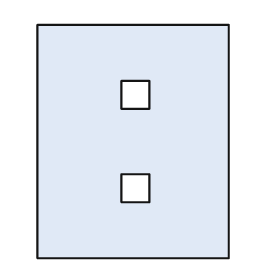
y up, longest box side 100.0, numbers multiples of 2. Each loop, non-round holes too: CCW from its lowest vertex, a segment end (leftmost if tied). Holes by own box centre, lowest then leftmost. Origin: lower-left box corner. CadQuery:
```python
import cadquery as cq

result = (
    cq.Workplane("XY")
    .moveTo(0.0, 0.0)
    .lineTo(82.0, 0.0)
    .lineTo(82.0, 100.0)
    .lineTo(0.0, 100.0)
    .close()
    .moveTo(36.0, 24.0)
    .lineTo(48.0, 24.0)
    .lineTo(48.0, 36.0)
    .lineTo(36.0, 36.0)
    .close()
    .moveTo(36.0, 64.0)
    .lineTo(48.0, 64.0)
    .lineTo(48.0, 76.0)
    .lineTo(36.0, 76.0)
    .close()
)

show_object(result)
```